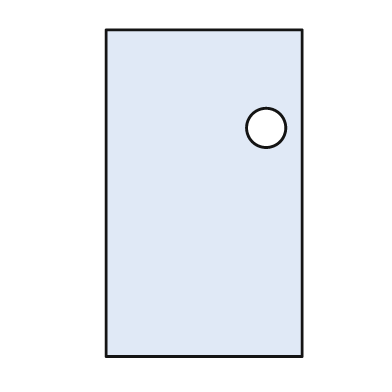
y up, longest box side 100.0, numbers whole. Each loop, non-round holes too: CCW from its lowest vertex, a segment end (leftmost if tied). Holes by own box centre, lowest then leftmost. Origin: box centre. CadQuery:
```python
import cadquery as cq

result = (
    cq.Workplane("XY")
    .moveTo(-30.0, -50.0)
    .lineTo(30.0, -50.0)
    .lineTo(30.0, 50.0)
    .lineTo(-30.0, 50.0)
    .close()
    .moveTo(19.0, 20.0)
    .circle(6.0)
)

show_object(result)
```